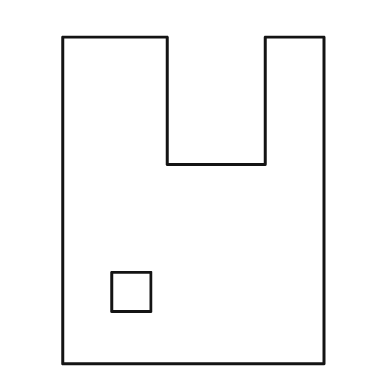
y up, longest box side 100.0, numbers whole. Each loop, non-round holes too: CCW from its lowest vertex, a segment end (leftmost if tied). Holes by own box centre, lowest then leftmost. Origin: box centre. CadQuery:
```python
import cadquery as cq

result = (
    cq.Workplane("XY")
    .moveTo(-40.0, -50.0)
    .lineTo(40.0, -50.0)
    .lineTo(40.0, 50.0)
    .lineTo(22.0, 50.0)
    .lineTo(22.0, 11.0)
    .lineTo(-8.0, 11.0)
    .lineTo(-8.0, 50.0)
    .lineTo(-40.0, 50.0)
    .close()
    .moveTo(-25.0, -34.0)
    .lineTo(-13.0, -34.0)
    .lineTo(-13.0, -22.0)
    .lineTo(-25.0, -22.0)
    .close()
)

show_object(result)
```